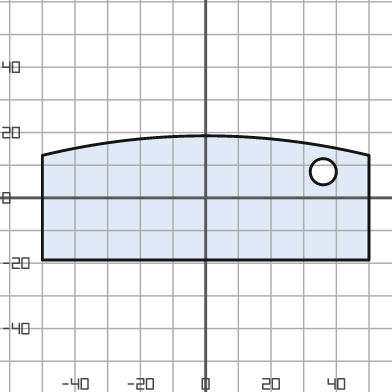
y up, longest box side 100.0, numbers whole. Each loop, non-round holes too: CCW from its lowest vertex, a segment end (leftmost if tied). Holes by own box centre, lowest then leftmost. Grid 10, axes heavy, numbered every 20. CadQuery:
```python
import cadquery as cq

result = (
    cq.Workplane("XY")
    .moveTo(-50.0, -19.0)
    .lineTo(50.0, -19.0)
    .lineTo(50.0, 13.0)
    .threePointArc((0.0, 19.0), (-50.0, 13.0))
    .close()
    .moveTo(36.0, 8.0)
    .circle(4.0)
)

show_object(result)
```